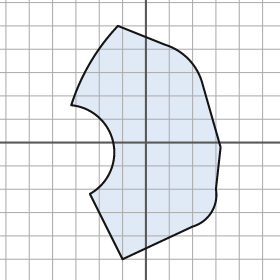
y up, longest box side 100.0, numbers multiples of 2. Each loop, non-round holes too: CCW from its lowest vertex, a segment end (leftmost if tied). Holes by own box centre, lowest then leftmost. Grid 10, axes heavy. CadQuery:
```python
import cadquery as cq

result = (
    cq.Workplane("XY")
    .moveTo(-10.0, -50.0)
    .lineTo(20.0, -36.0)
    .threePointArc((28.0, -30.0), (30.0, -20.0))
    .lineTo(32.0, -2.0)
    .lineTo(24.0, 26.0)
    .threePointArc((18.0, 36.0), (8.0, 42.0))
    .lineTo(-12.0, 50.0)
    .threePointArc((-24.0, 34.0), (-32.0, 16.0))
    .threePointArc((-14.0, 0.0), (-24.0, -22.0))
    .close()
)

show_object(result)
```